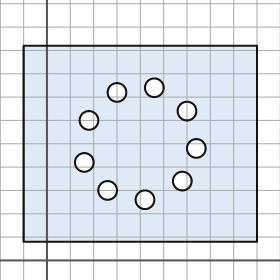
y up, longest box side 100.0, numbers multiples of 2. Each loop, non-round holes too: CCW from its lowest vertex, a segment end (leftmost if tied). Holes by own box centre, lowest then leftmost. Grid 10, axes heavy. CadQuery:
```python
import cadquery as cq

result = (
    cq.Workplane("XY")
    .moveTo(-10.0, 8.0)
    .lineTo(90.0, 8.0)
    .lineTo(90.0, 92.0)
    .lineTo(-10.0, 92.0)
    .close()
    .moveTo(42.0, 26.0)
    .circle(4.0)
    .moveTo(26.0, 30.0)
    .circle(4.0)
    .moveTo(58.0, 34.0)
    .circle(4.0)
    .moveTo(16.0, 42.0)
    .circle(4.0)
    .moveTo(64.0, 48.0)
    .circle(4.0)
    .moveTo(18.0, 60.0)
    .circle(4.0)
    .moveTo(60.0, 64.0)
    .circle(4.0)
    .moveTo(30.0, 72.0)
    .circle(4.0)
    .moveTo(46.0, 74.0)
    .circle(4.0)
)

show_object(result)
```